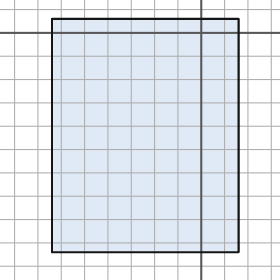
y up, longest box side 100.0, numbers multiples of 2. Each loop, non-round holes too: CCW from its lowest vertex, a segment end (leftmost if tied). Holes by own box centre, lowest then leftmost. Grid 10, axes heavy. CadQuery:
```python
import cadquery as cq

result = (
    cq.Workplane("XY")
    .moveTo(-64.0, -94.0)
    .lineTo(16.0, -94.0)
    .lineTo(16.0, 6.0)
    .lineTo(-64.0, 6.0)
    .close()
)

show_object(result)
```